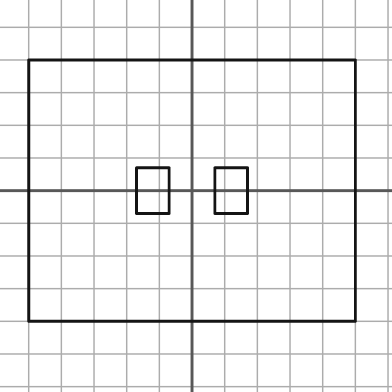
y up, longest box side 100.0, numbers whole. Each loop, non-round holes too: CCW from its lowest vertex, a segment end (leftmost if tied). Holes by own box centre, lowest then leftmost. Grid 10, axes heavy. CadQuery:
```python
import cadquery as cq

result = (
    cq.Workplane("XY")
    .moveTo(-50.0, -40.0)
    .lineTo(50.0, -40.0)
    .lineTo(50.0, 40.0)
    .lineTo(-50.0, 40.0)
    .close()
    .moveTo(-17.0, -7.0)
    .lineTo(-7.0, -7.0)
    .lineTo(-7.0, 7.0)
    .lineTo(-17.0, 7.0)
    .close()
    .moveTo(7.0, -7.0)
    .lineTo(17.0, -7.0)
    .lineTo(17.0, 7.0)
    .lineTo(7.0, 7.0)
    .close()
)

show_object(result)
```